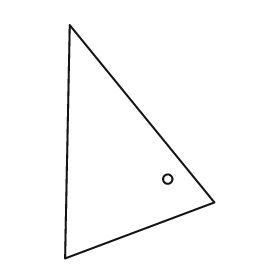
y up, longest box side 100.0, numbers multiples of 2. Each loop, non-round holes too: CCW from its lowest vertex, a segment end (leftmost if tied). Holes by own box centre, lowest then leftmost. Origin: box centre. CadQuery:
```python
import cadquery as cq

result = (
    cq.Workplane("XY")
    .moveTo(-32.0, -50.0)
    .lineTo(32.0, -26.0)
    .lineTo(-30.0, 50.0)
    .close()
    .moveTo(12.0, -16.0)
    .circle(2.0)
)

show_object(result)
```